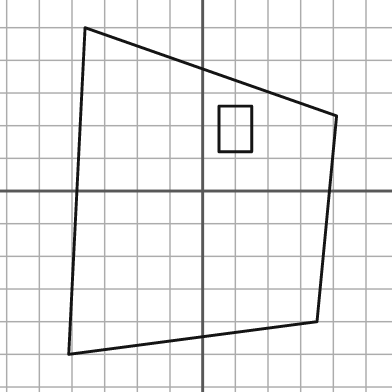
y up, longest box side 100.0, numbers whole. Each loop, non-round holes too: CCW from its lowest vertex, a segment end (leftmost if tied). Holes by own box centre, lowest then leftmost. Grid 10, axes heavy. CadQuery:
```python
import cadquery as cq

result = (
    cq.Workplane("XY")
    .moveTo(-41.0, -50.0)
    .lineTo(35.0, -40.0)
    .lineTo(41.0, 23.0)
    .lineTo(-36.0, 50.0)
    .close()
    .moveTo(5.0, 12.0)
    .lineTo(15.0, 12.0)
    .lineTo(15.0, 26.0)
    .lineTo(5.0, 26.0)
    .close()
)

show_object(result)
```